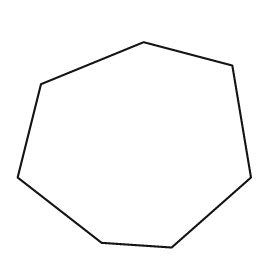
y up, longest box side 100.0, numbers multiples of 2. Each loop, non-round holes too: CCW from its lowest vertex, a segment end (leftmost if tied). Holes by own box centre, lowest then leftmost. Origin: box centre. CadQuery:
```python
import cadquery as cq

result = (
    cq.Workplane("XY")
    .moveTo(16.0, -44.0)
    .lineTo(50.0, -14.0)
    .lineTo(42.0, 34.0)
    .lineTo(4.0, 44.0)
    .lineTo(-40.0, 26.0)
    .lineTo(-50.0, -14.0)
    .lineTo(-14.0, -42.0)
    .close()
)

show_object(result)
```